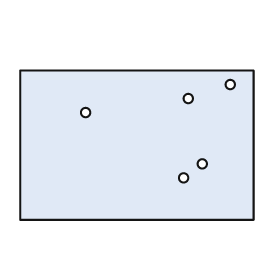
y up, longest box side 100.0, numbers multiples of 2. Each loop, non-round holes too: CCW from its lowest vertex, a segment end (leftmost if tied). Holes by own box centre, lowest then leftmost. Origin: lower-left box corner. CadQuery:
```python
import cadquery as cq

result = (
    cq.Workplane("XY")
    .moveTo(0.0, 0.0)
    .lineTo(100.0, 0.0)
    .lineTo(100.0, 64.0)
    .lineTo(0.0, 64.0)
    .close()
    .moveTo(70.0, 18.0)
    .circle(2.0)
    .moveTo(78.0, 24.0)
    .circle(2.0)
    .moveTo(28.0, 46.0)
    .circle(2.0)
    .moveTo(72.0, 52.0)
    .circle(2.0)
    .moveTo(90.0, 58.0)
    .circle(2.0)
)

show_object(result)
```